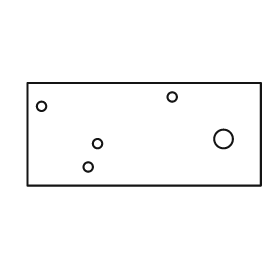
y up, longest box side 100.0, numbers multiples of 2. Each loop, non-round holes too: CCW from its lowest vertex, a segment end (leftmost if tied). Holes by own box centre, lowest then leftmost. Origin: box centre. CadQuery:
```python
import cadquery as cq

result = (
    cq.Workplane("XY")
    .moveTo(-50.0, -22.0)
    .lineTo(50.0, -22.0)
    .lineTo(50.0, 22.0)
    .lineTo(-50.0, 22.0)
    .close()
    .moveTo(-24.0, -14.0)
    .circle(2.0)
    .moveTo(-20.0, -4.0)
    .circle(2.0)
    .moveTo(34.0, -2.0)
    .circle(4.0)
    .moveTo(-44.0, 12.0)
    .circle(2.0)
    .moveTo(12.0, 16.0)
    .circle(2.0)
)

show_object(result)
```